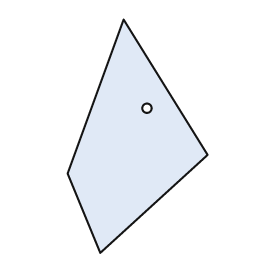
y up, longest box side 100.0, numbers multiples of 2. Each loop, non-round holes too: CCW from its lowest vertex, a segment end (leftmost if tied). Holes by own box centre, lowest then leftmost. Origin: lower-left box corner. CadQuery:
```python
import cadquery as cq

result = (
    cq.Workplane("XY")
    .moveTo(14.0, 0.0)
    .lineTo(60.0, 42.0)
    .lineTo(24.0, 100.0)
    .lineTo(0.0, 34.0)
    .close()
    .moveTo(34.0, 62.0)
    .circle(2.0)
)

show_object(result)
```